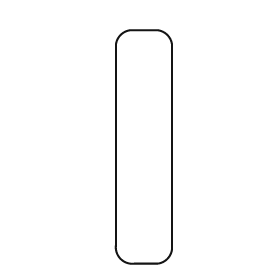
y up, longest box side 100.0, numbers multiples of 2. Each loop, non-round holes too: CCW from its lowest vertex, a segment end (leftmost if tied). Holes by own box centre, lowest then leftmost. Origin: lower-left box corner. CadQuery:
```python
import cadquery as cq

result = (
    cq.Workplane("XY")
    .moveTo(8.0, 0.0)
    .lineTo(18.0, 0.0)
    .threePointArc((22.0, 2.0), (24.0, 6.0))
    .lineTo(24.0, 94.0)
    .threePointArc((22.0, 98.0), (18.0, 100.0))
    .lineTo(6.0, 100.0)
    .threePointArc((2.0, 98.0), (0.0, 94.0))
    .lineTo(0.0, 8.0)
    .threePointArc((2.0, 2.0), (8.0, 0.0))
    .close()
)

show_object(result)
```